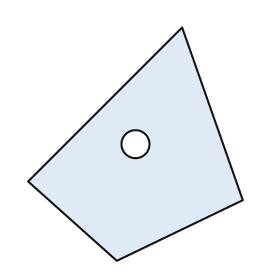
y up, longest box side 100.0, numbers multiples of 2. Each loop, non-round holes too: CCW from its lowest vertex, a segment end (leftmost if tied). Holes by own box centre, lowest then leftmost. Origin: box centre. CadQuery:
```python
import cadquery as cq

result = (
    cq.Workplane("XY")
    .moveTo(-8.0, -50.0)
    .lineTo(46.0, -24.0)
    .lineTo(20.0, 50.0)
    .lineTo(-46.0, -16.0)
    .close()
    .moveTo(0.0, 0.0)
    .circle(6.0)
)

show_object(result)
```